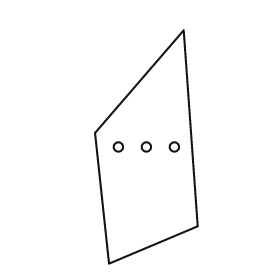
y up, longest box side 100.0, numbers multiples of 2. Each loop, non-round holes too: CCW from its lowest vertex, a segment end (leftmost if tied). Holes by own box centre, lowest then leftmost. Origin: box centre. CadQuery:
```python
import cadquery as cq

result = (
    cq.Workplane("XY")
    .moveTo(-16.0, -50.0)
    .lineTo(22.0, -34.0)
    .lineTo(16.0, 50.0)
    .lineTo(-22.0, 6.0)
    .close()
    .moveTo(-12.0, 0.0)
    .circle(2.0)
    .moveTo(0.0, 0.0)
    .circle(2.0)
    .moveTo(12.0, 0.0)
    .circle(2.0)
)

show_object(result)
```